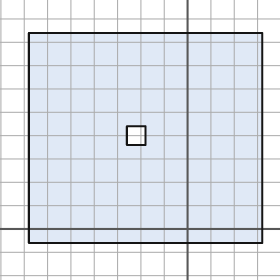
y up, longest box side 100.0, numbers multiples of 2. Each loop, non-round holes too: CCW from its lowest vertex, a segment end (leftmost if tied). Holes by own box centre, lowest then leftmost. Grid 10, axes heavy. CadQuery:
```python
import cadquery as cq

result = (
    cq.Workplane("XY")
    .moveTo(-68.0, -6.0)
    .lineTo(32.0, -6.0)
    .lineTo(32.0, 84.0)
    .lineTo(-68.0, 84.0)
    .close()
    .moveTo(-26.0, 36.0)
    .lineTo(-18.0, 36.0)
    .lineTo(-18.0, 44.0)
    .lineTo(-26.0, 44.0)
    .close()
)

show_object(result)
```